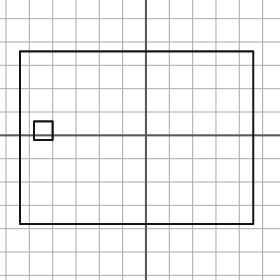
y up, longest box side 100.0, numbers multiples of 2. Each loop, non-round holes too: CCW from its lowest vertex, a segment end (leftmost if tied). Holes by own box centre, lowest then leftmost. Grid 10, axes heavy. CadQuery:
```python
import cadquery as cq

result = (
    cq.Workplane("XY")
    .moveTo(-54.0, -38.0)
    .lineTo(46.0, -38.0)
    .lineTo(46.0, 36.0)
    .lineTo(-54.0, 36.0)
    .close()
    .moveTo(-48.0, -2.0)
    .lineTo(-40.0, -2.0)
    .lineTo(-40.0, 6.0)
    .lineTo(-48.0, 6.0)
    .close()
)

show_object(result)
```